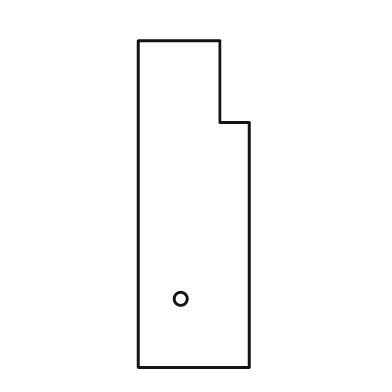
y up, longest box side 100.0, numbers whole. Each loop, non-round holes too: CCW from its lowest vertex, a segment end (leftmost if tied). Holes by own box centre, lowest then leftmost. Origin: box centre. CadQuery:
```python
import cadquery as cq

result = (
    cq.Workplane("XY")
    .moveTo(-17.0, -50.0)
    .lineTo(17.0, -50.0)
    .lineTo(17.0, 25.0)
    .lineTo(8.0, 25.0)
    .lineTo(8.0, 50.0)
    .lineTo(-17.0, 50.0)
    .close()
    .moveTo(-4.0, -29.0)
    .circle(2.0)
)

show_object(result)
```